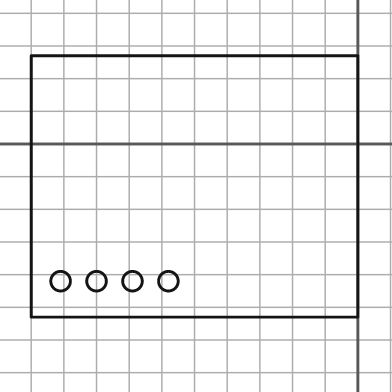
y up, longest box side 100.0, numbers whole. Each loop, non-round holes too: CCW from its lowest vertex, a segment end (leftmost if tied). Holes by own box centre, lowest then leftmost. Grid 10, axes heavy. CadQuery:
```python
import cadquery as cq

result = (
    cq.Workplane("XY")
    .moveTo(-100.0, -53.0)
    .lineTo(0.0, -53.0)
    .lineTo(0.0, 27.0)
    .lineTo(-100.0, 27.0)
    .close()
    .moveTo(-91.0, -42.0)
    .circle(3.0)
    .moveTo(-80.0, -42.0)
    .circle(3.0)
    .moveTo(-69.0, -42.0)
    .circle(3.0)
    .moveTo(-58.0, -42.0)
    .circle(3.0)
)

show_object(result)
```